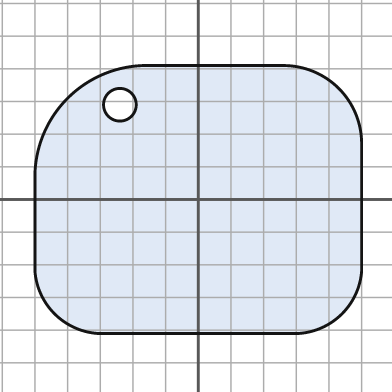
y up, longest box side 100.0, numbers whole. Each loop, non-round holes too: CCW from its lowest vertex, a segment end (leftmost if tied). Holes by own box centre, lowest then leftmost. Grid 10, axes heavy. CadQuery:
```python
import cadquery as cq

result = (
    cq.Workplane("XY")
    .moveTo(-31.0, -41.0)
    .lineTo(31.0, -41.0)
    .threePointArc((44.0, -35.0), (50.0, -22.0))
    .lineTo(50.0, 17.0)
    .threePointArc((43.0, 34.0), (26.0, 41.0))
    .lineTo(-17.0, 41.0)
    .threePointArc((-40.0, 31.0), (-50.0, 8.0))
    .lineTo(-50.0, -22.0)
    .threePointArc((-44.0, -35.0), (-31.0, -41.0))
    .close()
    .moveTo(-24.0, 29.0)
    .circle(5.0)
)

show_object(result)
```